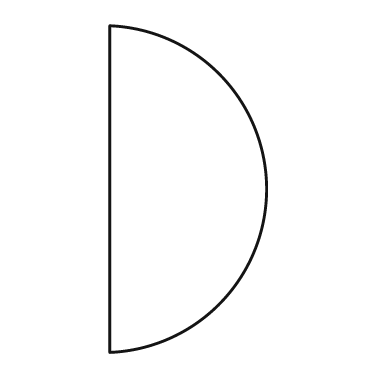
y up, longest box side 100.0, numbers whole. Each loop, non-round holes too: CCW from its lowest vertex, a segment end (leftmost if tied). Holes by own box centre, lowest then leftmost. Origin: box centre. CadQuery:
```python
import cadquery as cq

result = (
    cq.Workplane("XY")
    .moveTo(-24.0, -50.0)
    .threePointArc((24.0, 0.0), (-24.0, 50.0))
    .close()
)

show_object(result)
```